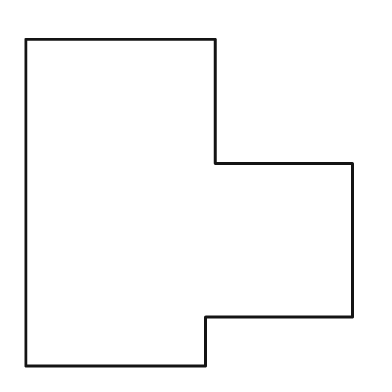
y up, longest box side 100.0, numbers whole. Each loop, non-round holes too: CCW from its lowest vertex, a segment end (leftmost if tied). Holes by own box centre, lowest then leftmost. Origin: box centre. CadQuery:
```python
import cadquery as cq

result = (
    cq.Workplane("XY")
    .moveTo(-50.0, -50.0)
    .lineTo(5.0, -50.0)
    .lineTo(5.0, -35.0)
    .lineTo(50.0, -35.0)
    .lineTo(50.0, 12.0)
    .lineTo(8.0, 12.0)
    .lineTo(8.0, 50.0)
    .lineTo(-50.0, 50.0)
    .close()
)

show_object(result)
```